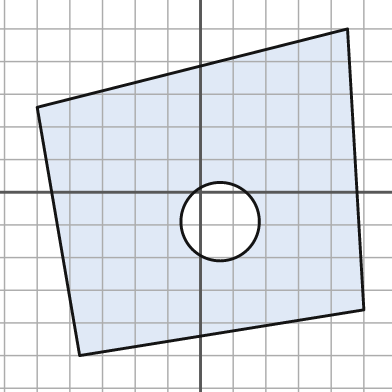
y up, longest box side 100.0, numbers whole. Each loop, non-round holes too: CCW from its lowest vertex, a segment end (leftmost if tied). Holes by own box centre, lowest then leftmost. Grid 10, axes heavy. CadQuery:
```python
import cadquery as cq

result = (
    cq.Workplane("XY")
    .moveTo(-37.0, -50.0)
    .lineTo(50.0, -36.0)
    .lineTo(45.0, 50.0)
    .lineTo(-50.0, 26.0)
    .close()
    .moveTo(6.0, -9.0)
    .circle(12.0)
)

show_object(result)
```